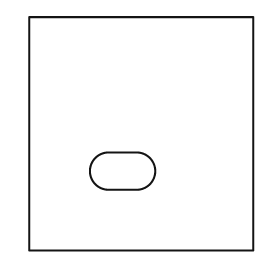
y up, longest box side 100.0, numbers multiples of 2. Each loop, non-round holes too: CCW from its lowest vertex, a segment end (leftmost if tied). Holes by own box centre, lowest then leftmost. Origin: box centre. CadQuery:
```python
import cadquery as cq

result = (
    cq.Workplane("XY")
    .moveTo(-48.0, -50.0)
    .lineTo(48.0, -50.0)
    .lineTo(48.0, 50.0)
    .lineTo(-48.0, 50.0)
    .close()
    .moveTo(-14.0, -24.0)
    .lineTo(-2.0, -24.0)
    .threePointArc((6.0, -16.0), (-2.0, -8.0))
    .lineTo(-14.0, -8.0)
    .threePointArc((-22.0, -16.0), (-14.0, -24.0))
    .close()
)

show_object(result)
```